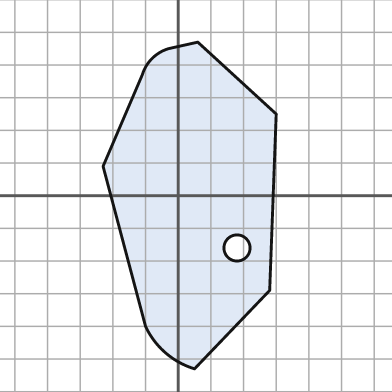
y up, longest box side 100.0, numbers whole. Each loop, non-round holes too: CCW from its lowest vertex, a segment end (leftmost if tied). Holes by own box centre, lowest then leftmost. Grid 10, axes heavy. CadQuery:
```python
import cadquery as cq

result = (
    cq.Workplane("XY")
    .moveTo(5.0, -53.0)
    .lineTo(28.0, -29.0)
    .lineTo(30.0, 25.0)
    .lineTo(6.0, 47.0)
    .lineTo(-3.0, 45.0)
    .threePointArc((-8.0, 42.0), (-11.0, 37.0))
    .lineTo(-23.0, 9.0)
    .lineTo(-10.0, -40.0)
    .threePointArc((-4.0, -48.0), (5.0, -53.0))
    .close()
    .moveTo(18.0, -16.0)
    .circle(4.0)
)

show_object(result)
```